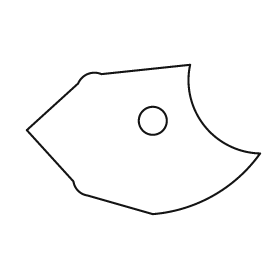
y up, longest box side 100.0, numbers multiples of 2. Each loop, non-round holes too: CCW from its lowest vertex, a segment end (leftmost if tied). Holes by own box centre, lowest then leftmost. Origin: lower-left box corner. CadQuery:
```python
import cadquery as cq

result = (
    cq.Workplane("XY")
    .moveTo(54.0, 0.0)
    .threePointArc((80.0, 8.0), (100.0, 26.0))
    .threePointArc((76.0, 38.0), (70.0, 64.0))
    .lineTo(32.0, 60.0)
    .threePointArc((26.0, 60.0), (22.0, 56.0))
    .lineTo(0.0, 36.0)
    .lineTo(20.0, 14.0)
    .threePointArc((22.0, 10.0), (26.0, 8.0))
    .close()
    .moveTo(54.0, 40.0)
    .circle(6.0)
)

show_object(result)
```